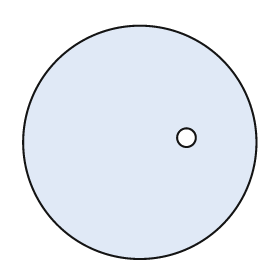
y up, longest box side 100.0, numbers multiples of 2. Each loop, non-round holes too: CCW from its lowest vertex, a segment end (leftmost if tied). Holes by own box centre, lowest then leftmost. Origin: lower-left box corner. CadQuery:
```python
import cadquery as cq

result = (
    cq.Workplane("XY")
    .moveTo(50.0, 50.0)
    .circle(50.0)
    .moveTo(70.0, 52.0)
    .circle(4.0)
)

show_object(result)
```